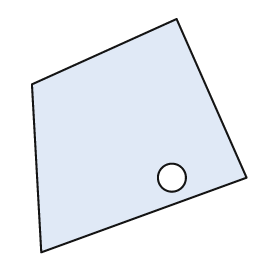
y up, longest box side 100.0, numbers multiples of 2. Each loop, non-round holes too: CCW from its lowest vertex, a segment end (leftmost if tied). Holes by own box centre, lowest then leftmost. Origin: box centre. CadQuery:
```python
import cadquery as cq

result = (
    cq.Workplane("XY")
    .moveTo(-42.0, -50.0)
    .lineTo(46.0, -18.0)
    .lineTo(16.0, 50.0)
    .lineTo(-46.0, 22.0)
    .close()
    .moveTo(14.0, -18.0)
    .circle(6.0)
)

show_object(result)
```